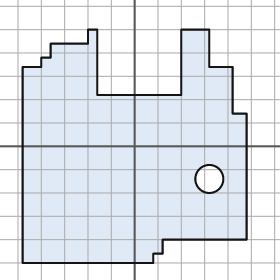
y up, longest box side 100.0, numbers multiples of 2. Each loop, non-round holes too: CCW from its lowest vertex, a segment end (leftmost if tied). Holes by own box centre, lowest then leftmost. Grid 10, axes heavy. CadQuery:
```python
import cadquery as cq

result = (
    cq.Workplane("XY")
    .moveTo(-48.0, -50.0)
    .lineTo(8.0, -50.0)
    .lineTo(8.0, -46.0)
    .lineTo(12.0, -46.0)
    .lineTo(12.0, -40.0)
    .lineTo(48.0, -40.0)
    .lineTo(48.0, 14.0)
    .lineTo(42.0, 14.0)
    .lineTo(42.0, 34.0)
    .lineTo(32.0, 34.0)
    .lineTo(32.0, 50.0)
    .lineTo(20.0, 50.0)
    .lineTo(20.0, 22.0)
    .lineTo(-16.0, 22.0)
    .lineTo(-16.0, 50.0)
    .lineTo(-20.0, 50.0)
    .lineTo(-20.0, 44.0)
    .lineTo(-36.0, 44.0)
    .lineTo(-36.0, 38.0)
    .lineTo(-40.0, 38.0)
    .lineTo(-40.0, 34.0)
    .lineTo(-48.0, 34.0)
    .close()
    .moveTo(32.0, -14.0)
    .circle(6.0)
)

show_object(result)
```